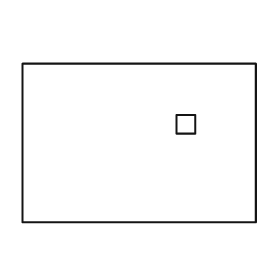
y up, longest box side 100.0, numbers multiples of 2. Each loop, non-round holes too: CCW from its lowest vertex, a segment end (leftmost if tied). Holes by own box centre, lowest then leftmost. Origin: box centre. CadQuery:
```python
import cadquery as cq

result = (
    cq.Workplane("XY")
    .moveTo(-50.0, -34.0)
    .lineTo(50.0, -34.0)
    .lineTo(50.0, 34.0)
    .lineTo(-50.0, 34.0)
    .close()
    .moveTo(16.0, 4.0)
    .lineTo(24.0, 4.0)
    .lineTo(24.0, 12.0)
    .lineTo(16.0, 12.0)
    .close()
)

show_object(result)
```